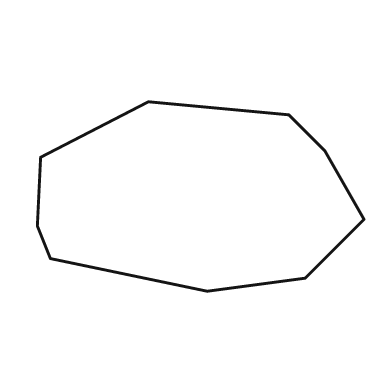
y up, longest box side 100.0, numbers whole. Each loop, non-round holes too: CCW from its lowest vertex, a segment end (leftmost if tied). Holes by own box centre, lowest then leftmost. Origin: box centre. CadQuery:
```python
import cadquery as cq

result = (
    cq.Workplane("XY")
    .moveTo(2.0, -29.0)
    .lineTo(32.0, -25.0)
    .lineTo(50.0, -7.0)
    .lineTo(38.0, 14.0)
    .lineTo(27.0, 25.0)
    .lineTo(-16.0, 29.0)
    .lineTo(-49.0, 12.0)
    .lineTo(-50.0, -9.0)
    .lineTo(-46.0, -19.0)
    .close()
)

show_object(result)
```